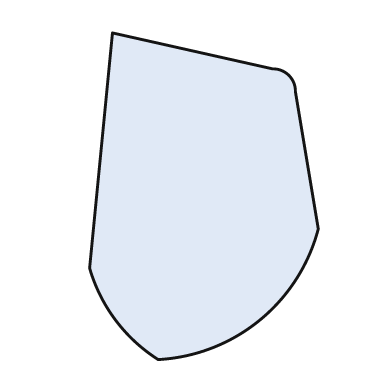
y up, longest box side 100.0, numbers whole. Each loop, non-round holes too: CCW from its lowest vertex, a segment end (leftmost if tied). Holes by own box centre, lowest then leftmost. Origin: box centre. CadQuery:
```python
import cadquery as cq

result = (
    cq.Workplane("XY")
    .moveTo(-14.0, -50.0)
    .threePointArc((17.0, -38.0), (35.0, -10.0))
    .lineTo(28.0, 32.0)
    .threePointArc((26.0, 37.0), (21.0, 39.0))
    .lineTo(-28.0, 50.0)
    .lineTo(-35.0, -22.0)
    .threePointArc((-27.0, -38.0), (-14.0, -50.0))
    .close()
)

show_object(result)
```